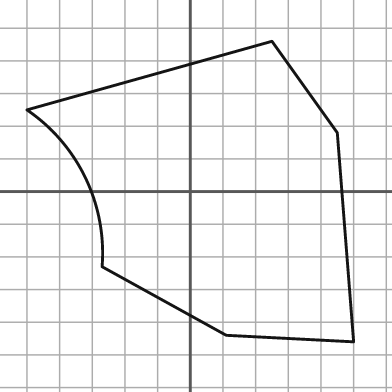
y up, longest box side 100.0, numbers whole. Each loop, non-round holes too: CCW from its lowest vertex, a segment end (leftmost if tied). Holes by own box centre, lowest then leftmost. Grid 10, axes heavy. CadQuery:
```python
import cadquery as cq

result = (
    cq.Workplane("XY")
    .moveTo(50.0, -46.0)
    .lineTo(45.0, 18.0)
    .lineTo(25.0, 46.0)
    .lineTo(-50.0, 25.0)
    .threePointArc((-32.0, 4.0), (-27.0, -23.0))
    .lineTo(11.0, -44.0)
    .close()
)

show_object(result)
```